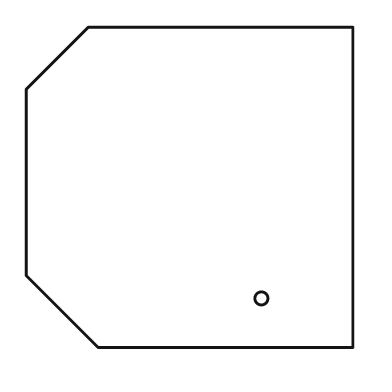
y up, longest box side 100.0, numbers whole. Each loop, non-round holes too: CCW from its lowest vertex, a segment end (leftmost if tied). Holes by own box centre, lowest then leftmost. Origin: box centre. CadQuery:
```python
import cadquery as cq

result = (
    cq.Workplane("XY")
    .moveTo(-28.0, -49.0)
    .lineTo(50.0, -49.0)
    .lineTo(50.0, 49.0)
    .lineTo(-31.0, 49.0)
    .lineTo(-50.0, 30.0)
    .lineTo(-50.0, -27.0)
    .close()
    .moveTo(22.0, -34.0)
    .circle(2.0)
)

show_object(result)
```